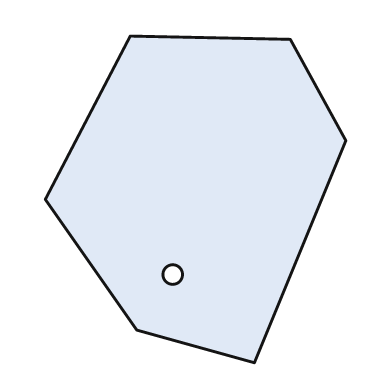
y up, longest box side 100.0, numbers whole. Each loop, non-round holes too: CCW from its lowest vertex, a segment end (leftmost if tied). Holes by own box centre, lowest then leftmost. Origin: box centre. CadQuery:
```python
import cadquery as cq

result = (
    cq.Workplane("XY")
    .moveTo(18.0, -50.0)
    .lineTo(46.0, 18.0)
    .lineTo(29.0, 49.0)
    .lineTo(-20.0, 50.0)
    .lineTo(-46.0, 0.0)
    .lineTo(-18.0, -40.0)
    .close()
    .moveTo(-7.0, -23.0)
    .circle(3.0)
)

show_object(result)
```